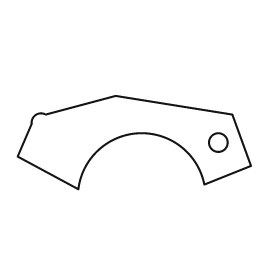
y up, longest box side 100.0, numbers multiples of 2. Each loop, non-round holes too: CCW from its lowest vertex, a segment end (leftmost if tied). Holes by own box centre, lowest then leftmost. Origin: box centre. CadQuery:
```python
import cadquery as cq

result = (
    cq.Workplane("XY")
    .moveTo(-24.0, -20.0)
    .threePointArc((2.0, 4.0), (30.0, -18.0))
    .lineTo(50.0, -10.0)
    .lineTo(42.0, 12.0)
    .lineTo(-8.0, 20.0)
    .lineTo(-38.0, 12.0)
    .threePointArc((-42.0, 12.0), (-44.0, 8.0))
    .lineTo(-50.0, -6.0)
    .close()
    .moveTo(36.0, 0.0)
    .circle(4.0)
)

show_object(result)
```